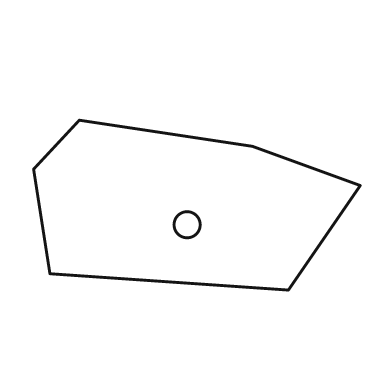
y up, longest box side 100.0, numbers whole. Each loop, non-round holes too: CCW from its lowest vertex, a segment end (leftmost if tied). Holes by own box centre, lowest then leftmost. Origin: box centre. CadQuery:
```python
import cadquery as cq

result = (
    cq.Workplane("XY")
    .moveTo(28.0, -26.0)
    .lineTo(50.0, 6.0)
    .lineTo(17.0, 18.0)
    .lineTo(-36.0, 26.0)
    .lineTo(-50.0, 11.0)
    .lineTo(-45.0, -21.0)
    .close()
    .moveTo(-3.0, -6.0)
    .circle(4.0)
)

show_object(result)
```